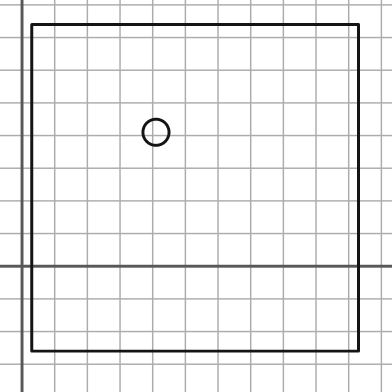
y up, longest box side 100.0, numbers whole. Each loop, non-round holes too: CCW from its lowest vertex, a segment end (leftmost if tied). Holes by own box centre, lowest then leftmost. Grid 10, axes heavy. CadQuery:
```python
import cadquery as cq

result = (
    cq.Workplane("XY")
    .moveTo(3.0, -26.0)
    .lineTo(103.0, -26.0)
    .lineTo(103.0, 74.0)
    .lineTo(3.0, 74.0)
    .close()
    .moveTo(41.0, 41.0)
    .circle(4.0)
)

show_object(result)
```